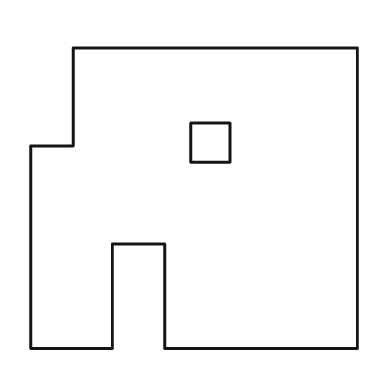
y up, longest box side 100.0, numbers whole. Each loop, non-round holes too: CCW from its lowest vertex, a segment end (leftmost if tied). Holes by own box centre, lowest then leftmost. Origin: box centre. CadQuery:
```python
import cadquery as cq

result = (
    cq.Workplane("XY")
    .moveTo(-50.0, -46.0)
    .lineTo(-25.0, -46.0)
    .lineTo(-25.0, -14.0)
    .lineTo(-9.0, -14.0)
    .lineTo(-9.0, -46.0)
    .lineTo(50.0, -46.0)
    .lineTo(50.0, 46.0)
    .lineTo(-37.0, 46.0)
    .lineTo(-37.0, 16.0)
    .lineTo(-50.0, 16.0)
    .close()
    .moveTo(-1.0, 11.0)
    .lineTo(11.0, 11.0)
    .lineTo(11.0, 23.0)
    .lineTo(-1.0, 23.0)
    .close()
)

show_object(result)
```